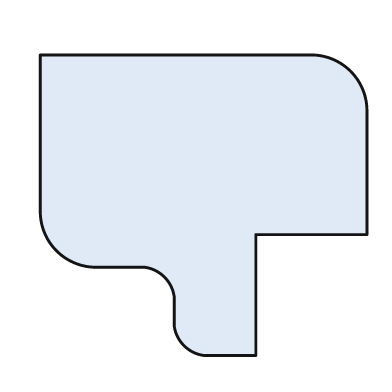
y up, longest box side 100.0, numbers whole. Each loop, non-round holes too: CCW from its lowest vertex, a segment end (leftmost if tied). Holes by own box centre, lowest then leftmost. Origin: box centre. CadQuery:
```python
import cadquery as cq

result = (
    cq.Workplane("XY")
    .moveTo(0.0, -46.0)
    .lineTo(16.0, -46.0)
    .lineTo(16.0, -9.0)
    .lineTo(50.0, -9.0)
    .lineTo(50.0, 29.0)
    .threePointArc((45.0, 41.0), (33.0, 46.0))
    .lineTo(-50.0, 46.0)
    .lineTo(-50.0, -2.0)
    .threePointArc((-45.0, -14.0), (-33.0, -19.0))
    .lineTo(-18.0, -19.0)
    .threePointArc((-12.0, -22.0), (-9.0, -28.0))
    .lineTo(-9.0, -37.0)
    .threePointArc((-6.0, -43.0), (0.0, -46.0))
    .close()
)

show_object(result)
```